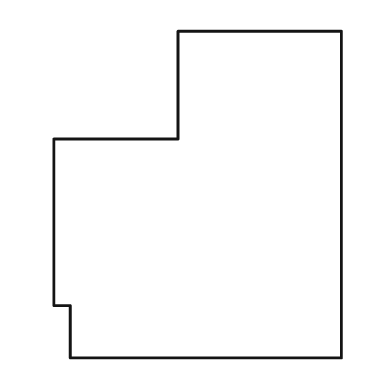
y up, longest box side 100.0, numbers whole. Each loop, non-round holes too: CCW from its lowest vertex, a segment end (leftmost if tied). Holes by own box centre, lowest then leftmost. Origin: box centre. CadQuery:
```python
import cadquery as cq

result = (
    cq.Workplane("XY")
    .moveTo(-39.0, -50.0)
    .lineTo(44.0, -50.0)
    .lineTo(44.0, 50.0)
    .lineTo(-6.0, 50.0)
    .lineTo(-6.0, 17.0)
    .lineTo(-44.0, 17.0)
    .lineTo(-44.0, -34.0)
    .lineTo(-39.0, -34.0)
    .close()
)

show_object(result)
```